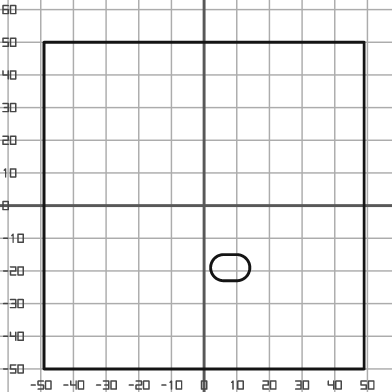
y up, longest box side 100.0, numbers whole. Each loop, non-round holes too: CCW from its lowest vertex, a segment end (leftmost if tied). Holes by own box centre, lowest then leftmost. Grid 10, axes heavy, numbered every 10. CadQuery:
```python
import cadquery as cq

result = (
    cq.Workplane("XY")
    .moveTo(-49.0, -50.0)
    .lineTo(49.0, -50.0)
    .lineTo(49.0, 50.0)
    .lineTo(-49.0, 50.0)
    .close()
    .moveTo(6.0, -23.0)
    .lineTo(10.0, -23.0)
    .threePointArc((14.0, -19.0), (10.0, -15.0))
    .lineTo(6.0, -15.0)
    .threePointArc((2.0, -19.0), (6.0, -23.0))
    .close()
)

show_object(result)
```